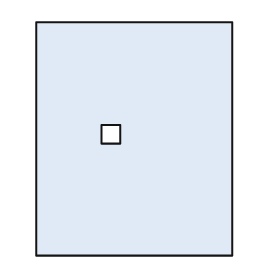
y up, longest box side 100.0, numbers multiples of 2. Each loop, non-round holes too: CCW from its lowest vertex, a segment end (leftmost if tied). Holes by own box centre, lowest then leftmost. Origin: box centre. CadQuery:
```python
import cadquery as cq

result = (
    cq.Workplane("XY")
    .moveTo(-42.0, -50.0)
    .lineTo(42.0, -50.0)
    .lineTo(42.0, 50.0)
    .lineTo(-42.0, 50.0)
    .close()
    .moveTo(-14.0, -2.0)
    .lineTo(-6.0, -2.0)
    .lineTo(-6.0, 6.0)
    .lineTo(-14.0, 6.0)
    .close()
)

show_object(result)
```